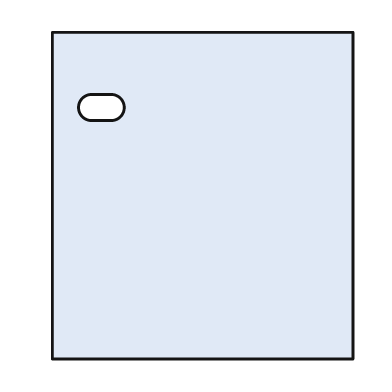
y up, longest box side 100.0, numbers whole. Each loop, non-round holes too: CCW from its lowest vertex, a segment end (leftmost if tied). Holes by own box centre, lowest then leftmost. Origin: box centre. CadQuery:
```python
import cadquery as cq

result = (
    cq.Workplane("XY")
    .moveTo(-46.0, -50.0)
    .lineTo(46.0, -50.0)
    .lineTo(46.0, 50.0)
    .lineTo(-46.0, 50.0)
    .close()
    .moveTo(-34.0, 23.0)
    .lineTo(-28.0, 23.0)
    .threePointArc((-24.0, 27.0), (-28.0, 31.0))
    .lineTo(-34.0, 31.0)
    .threePointArc((-38.0, 27.0), (-34.0, 23.0))
    .close()
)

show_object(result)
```